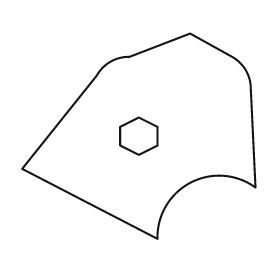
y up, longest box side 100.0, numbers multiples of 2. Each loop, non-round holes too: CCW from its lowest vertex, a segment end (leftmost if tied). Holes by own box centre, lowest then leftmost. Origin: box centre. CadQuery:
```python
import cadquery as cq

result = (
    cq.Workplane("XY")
    .moveTo(8.0, -44.0)
    .threePointArc((22.0, -20.0), (50.0, -22.0))
    .lineTo(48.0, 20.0)
    .threePointArc((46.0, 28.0), (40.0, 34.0))
    .lineTo(22.0, 44.0)
    .lineTo(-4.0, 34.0)
    .threePointArc((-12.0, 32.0), (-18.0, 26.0))
    .lineTo(-50.0, -14.0)
    .close()
    .moveTo(0.0, -8.0)
    .lineTo(8.0, -4.0)
    .lineTo(8.0, 4.0)
    .lineTo(0.0, 8.0)
    .lineTo(-8.0, 4.0)
    .lineTo(-8.0, -4.0)
    .close()
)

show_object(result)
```